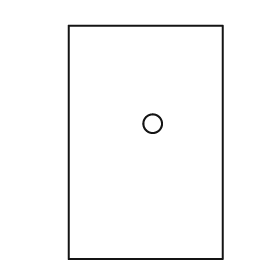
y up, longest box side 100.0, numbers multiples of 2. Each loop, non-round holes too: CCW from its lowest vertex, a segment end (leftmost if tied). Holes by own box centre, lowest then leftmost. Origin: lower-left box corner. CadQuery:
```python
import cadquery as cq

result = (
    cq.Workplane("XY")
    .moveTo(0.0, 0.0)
    .lineTo(66.0, 0.0)
    .lineTo(66.0, 100.0)
    .lineTo(0.0, 100.0)
    .close()
    .moveTo(36.0, 58.0)
    .circle(4.0)
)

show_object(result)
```